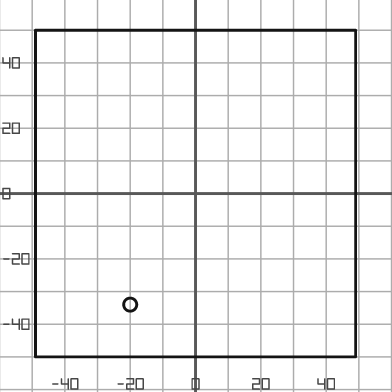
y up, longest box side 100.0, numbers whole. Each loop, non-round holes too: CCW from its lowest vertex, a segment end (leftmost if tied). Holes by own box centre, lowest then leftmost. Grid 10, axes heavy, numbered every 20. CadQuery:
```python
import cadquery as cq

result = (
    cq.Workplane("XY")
    .moveTo(-49.0, -50.0)
    .lineTo(49.0, -50.0)
    .lineTo(49.0, 50.0)
    .lineTo(-49.0, 50.0)
    .close()
    .moveTo(-20.0, -34.0)
    .circle(2.0)
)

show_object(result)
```